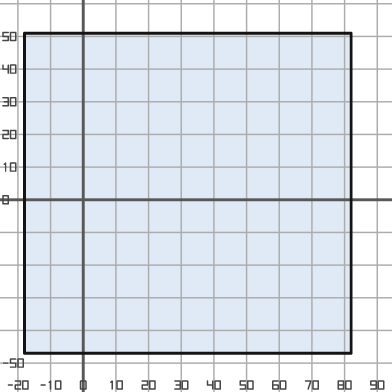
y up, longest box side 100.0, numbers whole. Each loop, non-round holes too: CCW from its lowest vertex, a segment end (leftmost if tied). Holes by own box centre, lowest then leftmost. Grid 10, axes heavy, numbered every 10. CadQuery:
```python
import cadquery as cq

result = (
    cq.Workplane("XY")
    .moveTo(-18.0, -47.0)
    .lineTo(82.0, -47.0)
    .lineTo(82.0, 51.0)
    .lineTo(-18.0, 51.0)
    .close()
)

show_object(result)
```